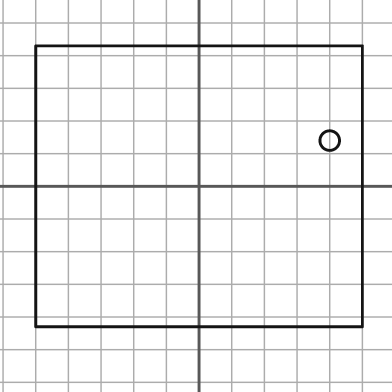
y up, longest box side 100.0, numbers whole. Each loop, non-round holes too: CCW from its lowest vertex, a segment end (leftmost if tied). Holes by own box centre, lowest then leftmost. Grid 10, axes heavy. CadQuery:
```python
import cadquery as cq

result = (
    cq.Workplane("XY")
    .moveTo(-50.0, -43.0)
    .lineTo(50.0, -43.0)
    .lineTo(50.0, 43.0)
    .lineTo(-50.0, 43.0)
    .close()
    .moveTo(40.0, 14.0)
    .circle(3.0)
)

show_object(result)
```